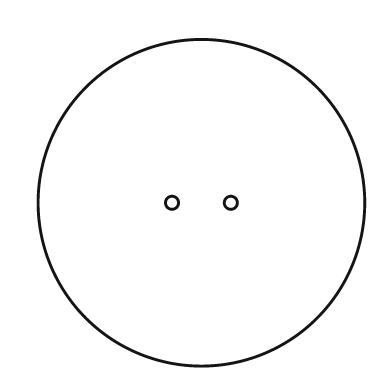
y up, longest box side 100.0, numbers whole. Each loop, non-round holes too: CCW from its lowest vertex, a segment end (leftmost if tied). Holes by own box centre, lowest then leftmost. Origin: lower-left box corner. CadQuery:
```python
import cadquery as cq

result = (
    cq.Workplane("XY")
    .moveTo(50.0, 50.0)
    .circle(50.0)
    .moveTo(41.0, 50.0)
    .circle(2.0)
    .moveTo(59.0, 50.0)
    .circle(2.0)
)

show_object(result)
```